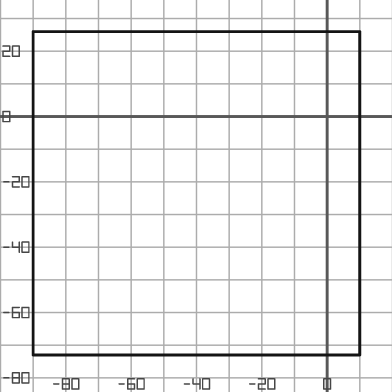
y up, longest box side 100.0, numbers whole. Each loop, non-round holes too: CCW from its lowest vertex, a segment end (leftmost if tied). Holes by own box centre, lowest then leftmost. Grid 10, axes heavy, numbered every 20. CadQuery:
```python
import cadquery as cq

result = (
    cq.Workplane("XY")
    .moveTo(-90.0, -73.0)
    .lineTo(10.0, -73.0)
    .lineTo(10.0, 26.0)
    .lineTo(-90.0, 26.0)
    .close()
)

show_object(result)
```